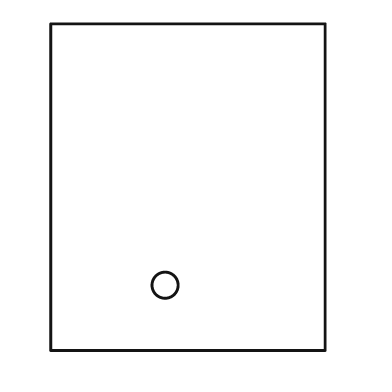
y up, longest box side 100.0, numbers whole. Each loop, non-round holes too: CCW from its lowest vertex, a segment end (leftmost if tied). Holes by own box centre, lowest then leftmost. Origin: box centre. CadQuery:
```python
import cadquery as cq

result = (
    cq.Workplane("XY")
    .moveTo(-42.0, -50.0)
    .lineTo(42.0, -50.0)
    .lineTo(42.0, 50.0)
    .lineTo(-42.0, 50.0)
    .close()
    .moveTo(-7.0, -30.0)
    .circle(4.0)
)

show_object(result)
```